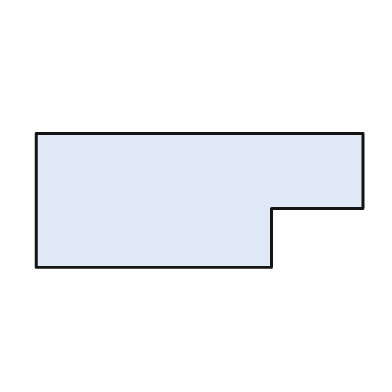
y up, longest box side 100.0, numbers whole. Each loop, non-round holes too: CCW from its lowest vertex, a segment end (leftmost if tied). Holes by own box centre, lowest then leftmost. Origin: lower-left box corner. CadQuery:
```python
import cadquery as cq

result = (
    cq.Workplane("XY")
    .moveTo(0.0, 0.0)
    .lineTo(72.0, 0.0)
    .lineTo(72.0, 18.0)
    .lineTo(100.0, 18.0)
    .lineTo(100.0, 41.0)
    .lineTo(0.0, 41.0)
    .close()
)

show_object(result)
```